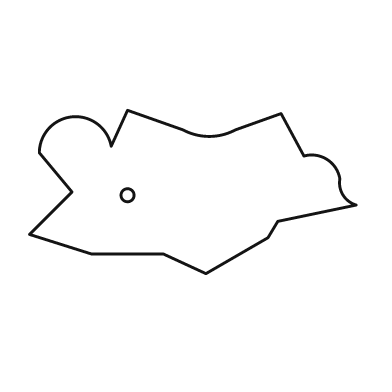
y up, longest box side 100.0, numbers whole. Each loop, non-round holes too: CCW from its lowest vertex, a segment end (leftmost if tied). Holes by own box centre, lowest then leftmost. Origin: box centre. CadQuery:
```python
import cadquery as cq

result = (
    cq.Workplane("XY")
    .moveTo(4.0, -25.0)
    .lineTo(23.0, -14.0)
    .lineTo(26.0, -9.0)
    .lineTo(50.0, -4.0)
    .threePointArc((46.0, -1.0), (45.0, 4.0))
    .threePointArc((41.0, 10.0), (34.0, 11.0))
    .lineTo(27.0, 24.0)
    .lineTo(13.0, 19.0)
    .threePointArc((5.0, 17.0), (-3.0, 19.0))
    .lineTo(-20.0, 25.0)
    .lineTo(-25.0, 14.0)
    .threePointArc((-37.0, 23.0), (-47.0, 12.0))
    .lineTo(-37.0, 0.0)
    .lineTo(-50.0, -13.0)
    .lineTo(-31.0, -19.0)
    .lineTo(-9.0, -19.0)
    .close()
    .moveTo(-20.0, -1.0)
    .circle(2.0)
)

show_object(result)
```